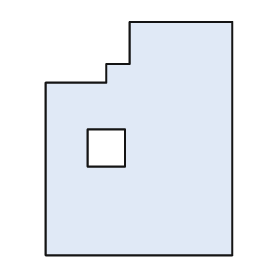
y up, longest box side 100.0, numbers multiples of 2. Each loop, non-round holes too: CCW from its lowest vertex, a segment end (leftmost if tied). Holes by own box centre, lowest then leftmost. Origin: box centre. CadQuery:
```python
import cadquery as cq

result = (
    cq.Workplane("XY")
    .moveTo(-40.0, -50.0)
    .lineTo(40.0, -50.0)
    .lineTo(40.0, 50.0)
    .lineTo(-4.0, 50.0)
    .lineTo(-4.0, 32.0)
    .lineTo(-14.0, 32.0)
    .lineTo(-14.0, 24.0)
    .lineTo(-40.0, 24.0)
    .close()
    .moveTo(-22.0, -12.0)
    .lineTo(-6.0, -12.0)
    .lineTo(-6.0, 4.0)
    .lineTo(-22.0, 4.0)
    .close()
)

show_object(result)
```